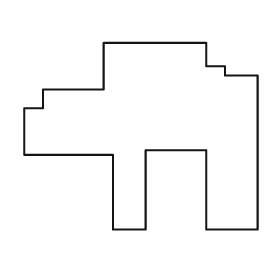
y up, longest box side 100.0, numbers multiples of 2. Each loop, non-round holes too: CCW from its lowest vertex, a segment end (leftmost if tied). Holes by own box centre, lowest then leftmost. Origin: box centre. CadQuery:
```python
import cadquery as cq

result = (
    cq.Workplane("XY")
    .moveTo(-12.0, -40.0)
    .lineTo(2.0, -40.0)
    .lineTo(2.0, -6.0)
    .lineTo(28.0, -6.0)
    .lineTo(28.0, -40.0)
    .lineTo(50.0, -40.0)
    .lineTo(50.0, 26.0)
    .lineTo(36.0, 26.0)
    .lineTo(36.0, 30.0)
    .lineTo(28.0, 30.0)
    .lineTo(28.0, 40.0)
    .lineTo(-16.0, 40.0)
    .lineTo(-16.0, 20.0)
    .lineTo(-42.0, 20.0)
    .lineTo(-42.0, 12.0)
    .lineTo(-50.0, 12.0)
    .lineTo(-50.0, -8.0)
    .lineTo(-12.0, -8.0)
    .close()
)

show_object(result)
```